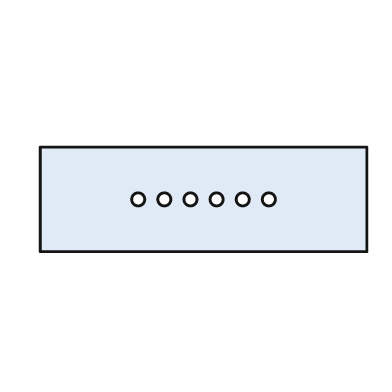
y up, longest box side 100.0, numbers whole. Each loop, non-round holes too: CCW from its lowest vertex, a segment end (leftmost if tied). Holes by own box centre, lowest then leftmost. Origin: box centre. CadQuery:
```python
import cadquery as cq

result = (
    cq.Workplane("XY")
    .moveTo(-50.0, -16.0)
    .lineTo(50.0, -16.0)
    .lineTo(50.0, 16.0)
    .lineTo(-50.0, 16.0)
    .close()
    .moveTo(-20.0, 0.0)
    .circle(2.0)
    .moveTo(-12.0, 0.0)
    .circle(2.0)
    .moveTo(-4.0, 0.0)
    .circle(2.0)
    .moveTo(4.0, 0.0)
    .circle(2.0)
    .moveTo(12.0, 0.0)
    .circle(2.0)
    .moveTo(20.0, 0.0)
    .circle(2.0)
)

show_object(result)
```